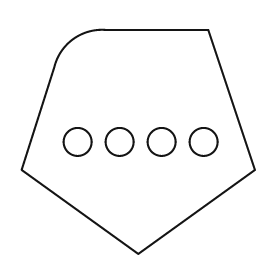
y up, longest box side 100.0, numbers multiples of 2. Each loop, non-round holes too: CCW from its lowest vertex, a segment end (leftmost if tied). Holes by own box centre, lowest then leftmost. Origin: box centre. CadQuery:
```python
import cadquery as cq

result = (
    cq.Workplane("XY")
    .moveTo(0.0, -48.0)
    .lineTo(50.0, -12.0)
    .lineTo(30.0, 48.0)
    .lineTo(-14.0, 48.0)
    .threePointArc((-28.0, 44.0), (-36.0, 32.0))
    .lineTo(-50.0, -12.0)
    .close()
    .moveTo(-26.0, 0.0)
    .circle(6.0)
    .moveTo(-8.0, 0.0)
    .circle(6.0)
    .moveTo(10.0, 0.0)
    .circle(6.0)
    .moveTo(28.0, 0.0)
    .circle(6.0)
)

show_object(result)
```